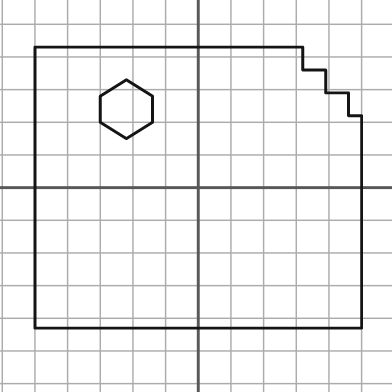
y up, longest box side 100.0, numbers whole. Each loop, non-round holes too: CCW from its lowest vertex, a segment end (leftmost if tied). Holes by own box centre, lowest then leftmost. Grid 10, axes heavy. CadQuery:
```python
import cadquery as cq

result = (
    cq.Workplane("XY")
    .moveTo(-50.0, -43.0)
    .lineTo(50.0, -43.0)
    .lineTo(50.0, 22.0)
    .lineTo(46.0, 22.0)
    .lineTo(46.0, 29.0)
    .lineTo(39.0, 29.0)
    .lineTo(39.0, 36.0)
    .lineTo(32.0, 36.0)
    .lineTo(32.0, 43.0)
    .lineTo(-50.0, 43.0)
    .close()
    .moveTo(-22.0, 15.0)
    .lineTo(-14.0, 20.0)
    .lineTo(-14.0, 28.0)
    .lineTo(-22.0, 33.0)
    .lineTo(-30.0, 28.0)
    .lineTo(-30.0, 20.0)
    .close()
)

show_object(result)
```